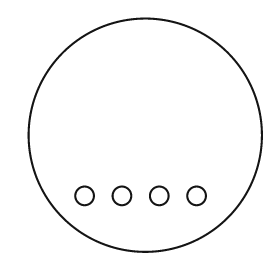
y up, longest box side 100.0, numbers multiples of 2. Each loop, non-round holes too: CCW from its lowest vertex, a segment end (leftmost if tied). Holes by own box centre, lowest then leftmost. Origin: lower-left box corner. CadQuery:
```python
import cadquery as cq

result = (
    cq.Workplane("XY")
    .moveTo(50.0, 50.0)
    .circle(50.0)
    .moveTo(24.0, 24.0)
    .circle(4.0)
    .moveTo(40.0, 24.0)
    .circle(4.0)
    .moveTo(56.0, 24.0)
    .circle(4.0)
    .moveTo(72.0, 24.0)
    .circle(4.0)
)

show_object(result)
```